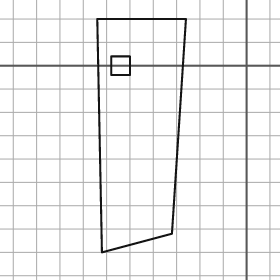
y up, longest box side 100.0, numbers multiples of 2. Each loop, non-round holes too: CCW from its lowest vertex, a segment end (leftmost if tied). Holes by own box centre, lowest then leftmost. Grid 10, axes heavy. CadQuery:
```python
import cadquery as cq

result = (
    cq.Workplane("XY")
    .moveTo(-62.0, -80.0)
    .lineTo(-32.0, -72.0)
    .lineTo(-26.0, 20.0)
    .lineTo(-64.0, 20.0)
    .close()
    .moveTo(-58.0, -4.0)
    .lineTo(-50.0, -4.0)
    .lineTo(-50.0, 4.0)
    .lineTo(-58.0, 4.0)
    .close()
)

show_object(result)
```